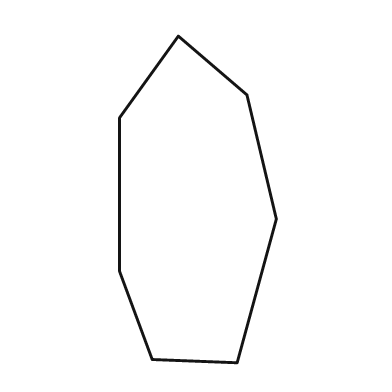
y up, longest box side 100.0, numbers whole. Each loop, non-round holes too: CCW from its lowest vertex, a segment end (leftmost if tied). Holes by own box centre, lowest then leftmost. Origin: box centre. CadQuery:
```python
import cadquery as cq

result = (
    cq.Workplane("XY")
    .moveTo(12.0, -50.0)
    .lineTo(24.0, -6.0)
    .lineTo(15.0, 32.0)
    .lineTo(-6.0, 50.0)
    .lineTo(-24.0, 25.0)
    .lineTo(-24.0, -22.0)
    .lineTo(-14.0, -49.0)
    .close()
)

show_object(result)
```